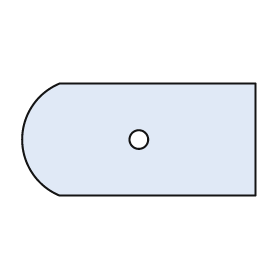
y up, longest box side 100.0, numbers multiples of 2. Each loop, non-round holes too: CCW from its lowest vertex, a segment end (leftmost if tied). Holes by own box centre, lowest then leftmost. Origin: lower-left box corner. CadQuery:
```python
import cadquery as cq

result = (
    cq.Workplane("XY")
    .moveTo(16.0, 0.0)
    .lineTo(100.0, 0.0)
    .lineTo(100.0, 48.0)
    .lineTo(16.0, 48.0)
    .threePointArc((0.0, 24.0), (16.0, 0.0))
    .close()
    .moveTo(50.0, 24.0)
    .circle(4.0)
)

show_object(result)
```